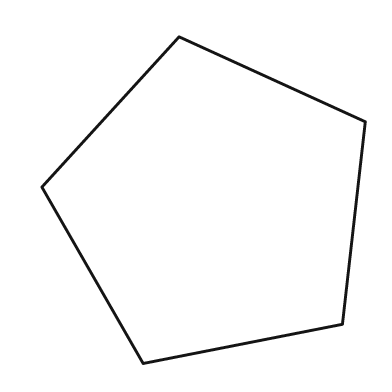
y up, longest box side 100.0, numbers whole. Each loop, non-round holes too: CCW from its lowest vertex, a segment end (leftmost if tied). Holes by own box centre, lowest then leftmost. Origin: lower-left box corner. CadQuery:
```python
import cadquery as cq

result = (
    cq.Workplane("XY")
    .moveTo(31.0, 0.0)
    .lineTo(92.0, 12.0)
    .lineTo(99.0, 74.0)
    .lineTo(42.0, 100.0)
    .lineTo(0.0, 54.0)
    .close()
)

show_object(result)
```